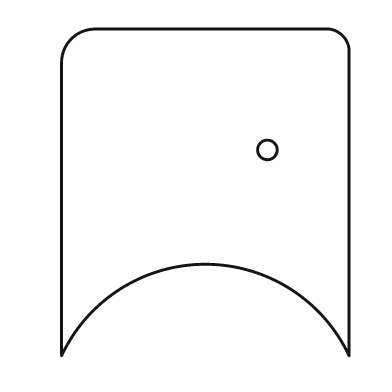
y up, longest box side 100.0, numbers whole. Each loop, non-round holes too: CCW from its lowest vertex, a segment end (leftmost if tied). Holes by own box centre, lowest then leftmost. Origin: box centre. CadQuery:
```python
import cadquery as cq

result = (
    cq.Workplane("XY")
    .moveTo(-44.0, -50.0)
    .threePointArc((0.0, -22.0), (44.0, -50.0))
    .lineTo(44.0, 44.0)
    .threePointArc((42.0, 48.0), (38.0, 50.0))
    .lineTo(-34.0, 50.0)
    .threePointArc((-41.0, 47.0), (-44.0, 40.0))
    .close()
    .moveTo(19.0, 13.0)
    .circle(3.0)
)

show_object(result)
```